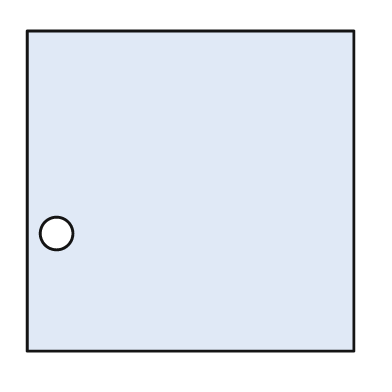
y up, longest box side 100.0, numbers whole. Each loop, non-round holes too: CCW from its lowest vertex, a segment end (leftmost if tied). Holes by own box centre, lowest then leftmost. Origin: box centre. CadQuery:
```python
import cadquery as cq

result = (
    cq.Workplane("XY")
    .moveTo(-50.0, -49.0)
    .lineTo(50.0, -49.0)
    .lineTo(50.0, 49.0)
    .lineTo(-50.0, 49.0)
    .close()
    .moveTo(-41.0, -13.0)
    .circle(5.0)
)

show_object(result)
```